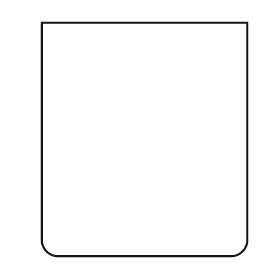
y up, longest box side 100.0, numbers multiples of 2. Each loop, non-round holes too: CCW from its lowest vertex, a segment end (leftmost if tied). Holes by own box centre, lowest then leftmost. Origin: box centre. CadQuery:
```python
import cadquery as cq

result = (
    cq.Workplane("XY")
    .moveTo(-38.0, -50.0)
    .lineTo(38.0, -50.0)
    .threePointArc((42.0, -48.0), (44.0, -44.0))
    .lineTo(44.0, 50.0)
    .lineTo(-44.0, 50.0)
    .lineTo(-44.0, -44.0)
    .threePointArc((-42.0, -48.0), (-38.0, -50.0))
    .close()
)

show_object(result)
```